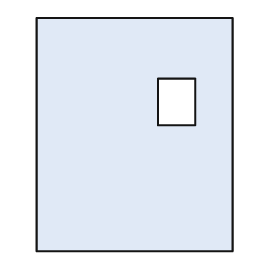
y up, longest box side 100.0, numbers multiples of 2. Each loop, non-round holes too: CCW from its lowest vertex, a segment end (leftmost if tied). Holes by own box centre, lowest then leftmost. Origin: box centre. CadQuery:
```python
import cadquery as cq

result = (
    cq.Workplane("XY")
    .moveTo(-42.0, -50.0)
    .lineTo(42.0, -50.0)
    .lineTo(42.0, 50.0)
    .lineTo(-42.0, 50.0)
    .close()
    .moveTo(10.0, 4.0)
    .lineTo(26.0, 4.0)
    .lineTo(26.0, 24.0)
    .lineTo(10.0, 24.0)
    .close()
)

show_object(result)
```